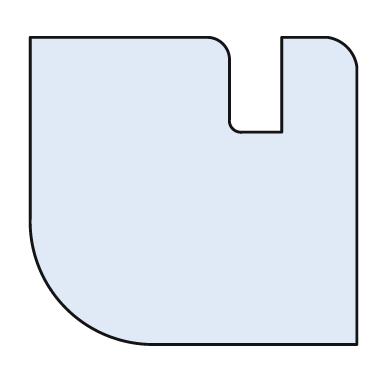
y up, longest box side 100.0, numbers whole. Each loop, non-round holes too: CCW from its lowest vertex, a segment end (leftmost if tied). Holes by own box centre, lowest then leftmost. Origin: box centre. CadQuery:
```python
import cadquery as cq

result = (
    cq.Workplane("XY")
    .moveTo(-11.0, -47.0)
    .lineTo(50.0, -47.0)
    .lineTo(50.0, 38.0)
    .threePointArc((47.0, 44.0), (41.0, 47.0))
    .lineTo(27.0, 47.0)
    .lineTo(27.0, 18.0)
    .lineTo(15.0, 18.0)
    .threePointArc((12.0, 19.0), (11.0, 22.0))
    .lineTo(11.0, 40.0)
    .threePointArc((9.0, 45.0), (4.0, 47.0))
    .lineTo(-50.0, 47.0)
    .lineTo(-50.0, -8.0)
    .threePointArc((-39.0, -36.0), (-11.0, -47.0))
    .close()
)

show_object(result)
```